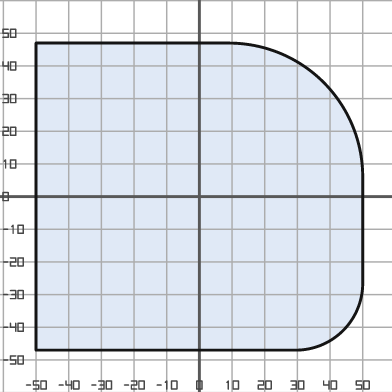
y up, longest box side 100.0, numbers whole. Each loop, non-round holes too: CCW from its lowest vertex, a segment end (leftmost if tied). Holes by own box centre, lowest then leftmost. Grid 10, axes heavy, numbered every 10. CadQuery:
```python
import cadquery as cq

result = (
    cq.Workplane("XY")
    .moveTo(-50.0, -47.0)
    .lineTo(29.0, -47.0)
    .threePointArc((44.0, -41.0), (50.0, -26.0))
    .lineTo(50.0, 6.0)
    .threePointArc((38.0, 35.0), (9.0, 47.0))
    .lineTo(-50.0, 47.0)
    .close()
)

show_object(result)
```